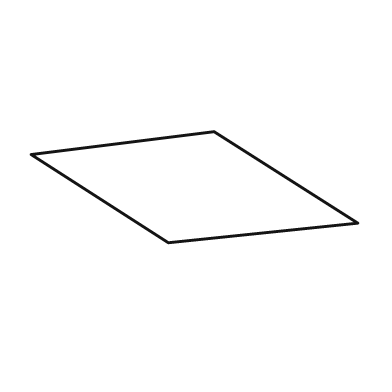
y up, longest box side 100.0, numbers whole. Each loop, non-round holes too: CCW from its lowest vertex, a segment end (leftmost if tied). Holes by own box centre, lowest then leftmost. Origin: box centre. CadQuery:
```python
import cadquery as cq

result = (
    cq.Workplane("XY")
    .moveTo(-8.0, -17.0)
    .lineTo(50.0, -11.0)
    .lineTo(6.0, 17.0)
    .lineTo(-50.0, 10.0)
    .close()
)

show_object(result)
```